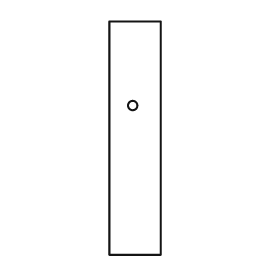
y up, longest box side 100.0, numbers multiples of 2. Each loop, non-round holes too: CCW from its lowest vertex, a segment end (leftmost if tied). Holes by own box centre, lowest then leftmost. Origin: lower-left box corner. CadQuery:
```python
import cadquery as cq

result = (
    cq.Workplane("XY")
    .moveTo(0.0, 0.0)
    .lineTo(22.0, 0.0)
    .lineTo(22.0, 100.0)
    .lineTo(0.0, 100.0)
    .close()
    .moveTo(10.0, 64.0)
    .circle(2.0)
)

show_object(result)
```